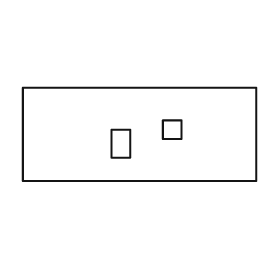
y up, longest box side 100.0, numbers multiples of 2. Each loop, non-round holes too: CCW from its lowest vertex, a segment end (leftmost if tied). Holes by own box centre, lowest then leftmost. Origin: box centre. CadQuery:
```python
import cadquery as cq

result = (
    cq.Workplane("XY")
    .moveTo(-50.0, -20.0)
    .lineTo(50.0, -20.0)
    .lineTo(50.0, 20.0)
    .lineTo(-50.0, 20.0)
    .close()
    .moveTo(-12.0, -10.0)
    .lineTo(-4.0, -10.0)
    .lineTo(-4.0, 2.0)
    .lineTo(-12.0, 2.0)
    .close()
    .moveTo(10.0, -2.0)
    .lineTo(18.0, -2.0)
    .lineTo(18.0, 6.0)
    .lineTo(10.0, 6.0)
    .close()
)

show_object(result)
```